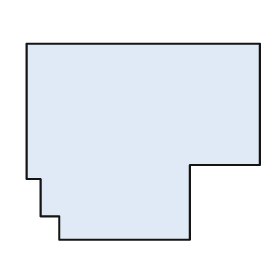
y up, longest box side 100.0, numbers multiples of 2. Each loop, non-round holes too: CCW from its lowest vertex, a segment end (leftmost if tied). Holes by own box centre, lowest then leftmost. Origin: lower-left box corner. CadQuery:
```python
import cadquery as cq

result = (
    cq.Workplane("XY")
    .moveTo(14.0, 0.0)
    .lineTo(70.0, 0.0)
    .lineTo(70.0, 32.0)
    .lineTo(100.0, 32.0)
    .lineTo(100.0, 84.0)
    .lineTo(0.0, 84.0)
    .lineTo(0.0, 26.0)
    .lineTo(6.0, 26.0)
    .lineTo(6.0, 10.0)
    .lineTo(14.0, 10.0)
    .close()
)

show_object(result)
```